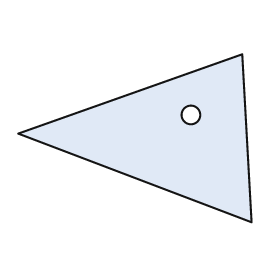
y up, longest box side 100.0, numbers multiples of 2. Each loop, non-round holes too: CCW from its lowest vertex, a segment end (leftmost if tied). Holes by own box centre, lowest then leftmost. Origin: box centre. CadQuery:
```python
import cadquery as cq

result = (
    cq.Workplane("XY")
    .moveTo(50.0, -36.0)
    .lineTo(46.0, 36.0)
    .lineTo(-50.0, 2.0)
    .close()
    .moveTo(24.0, 10.0)
    .circle(4.0)
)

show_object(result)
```